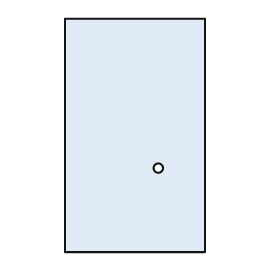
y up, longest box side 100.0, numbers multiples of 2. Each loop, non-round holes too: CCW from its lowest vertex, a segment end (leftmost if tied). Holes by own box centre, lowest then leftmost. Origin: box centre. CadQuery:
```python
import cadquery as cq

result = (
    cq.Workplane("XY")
    .moveTo(-30.0, -50.0)
    .lineTo(30.0, -50.0)
    .lineTo(30.0, 50.0)
    .lineTo(-30.0, 50.0)
    .close()
    .moveTo(10.0, -14.0)
    .circle(2.0)
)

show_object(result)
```